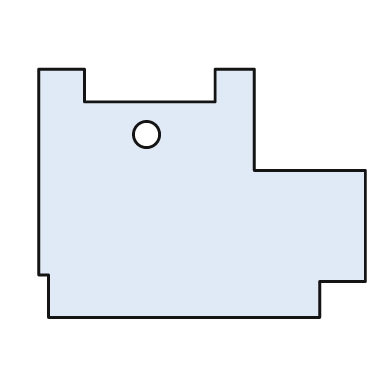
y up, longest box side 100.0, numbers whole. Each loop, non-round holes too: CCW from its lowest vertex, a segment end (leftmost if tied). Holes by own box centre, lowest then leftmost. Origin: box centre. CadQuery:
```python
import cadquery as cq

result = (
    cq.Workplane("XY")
    .moveTo(-47.0, -38.0)
    .lineTo(36.0, -38.0)
    .lineTo(36.0, -27.0)
    .lineTo(50.0, -27.0)
    .lineTo(50.0, 7.0)
    .lineTo(16.0, 7.0)
    .lineTo(16.0, 38.0)
    .lineTo(4.0, 38.0)
    .lineTo(4.0, 28.0)
    .lineTo(-36.0, 28.0)
    .lineTo(-36.0, 38.0)
    .lineTo(-50.0, 38.0)
    .lineTo(-50.0, -25.0)
    .lineTo(-47.0, -25.0)
    .close()
    .moveTo(-17.0, 18.0)
    .circle(4.0)
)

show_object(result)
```